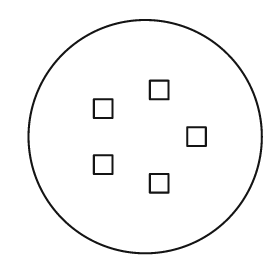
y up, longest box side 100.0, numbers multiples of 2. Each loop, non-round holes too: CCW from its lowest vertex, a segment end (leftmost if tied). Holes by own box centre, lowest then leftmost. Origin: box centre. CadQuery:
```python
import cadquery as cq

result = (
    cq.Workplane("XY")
    .moveTo(0.0, 0.0)
    .circle(50.0)
    .moveTo(2.0, -24.0)
    .lineTo(10.0, -24.0)
    .lineTo(10.0, -16.0)
    .lineTo(2.0, -16.0)
    .close()
    .moveTo(-22.0, -16.0)
    .lineTo(-14.0, -16.0)
    .lineTo(-14.0, -8.0)
    .lineTo(-22.0, -8.0)
    .close()
    .moveTo(18.0, -4.0)
    .lineTo(26.0, -4.0)
    .lineTo(26.0, 4.0)
    .lineTo(18.0, 4.0)
    .close()
    .moveTo(-22.0, 8.0)
    .lineTo(-14.0, 8.0)
    .lineTo(-14.0, 16.0)
    .lineTo(-22.0, 16.0)
    .close()
    .moveTo(2.0, 16.0)
    .lineTo(10.0, 16.0)
    .lineTo(10.0, 24.0)
    .lineTo(2.0, 24.0)
    .close()
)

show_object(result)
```